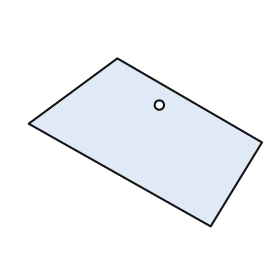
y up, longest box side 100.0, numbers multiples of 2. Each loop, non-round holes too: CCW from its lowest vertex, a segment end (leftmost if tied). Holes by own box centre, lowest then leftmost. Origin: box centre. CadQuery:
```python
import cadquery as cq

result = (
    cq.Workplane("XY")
    .moveTo(28.0, -36.0)
    .lineTo(50.0, 0.0)
    .lineTo(-12.0, 36.0)
    .lineTo(-50.0, 8.0)
    .close()
    .moveTo(6.0, 16.0)
    .circle(2.0)
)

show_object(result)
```